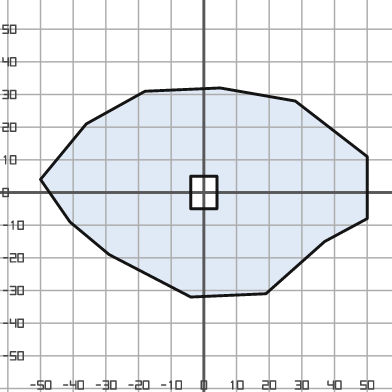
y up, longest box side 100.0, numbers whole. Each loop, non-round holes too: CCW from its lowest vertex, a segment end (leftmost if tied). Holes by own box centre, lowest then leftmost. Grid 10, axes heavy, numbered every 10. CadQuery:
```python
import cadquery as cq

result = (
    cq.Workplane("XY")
    .moveTo(-4.0, -32.0)
    .lineTo(19.0, -31.0)
    .lineTo(37.0, -15.0)
    .lineTo(50.0, -8.0)
    .lineTo(50.0, 11.0)
    .lineTo(28.0, 28.0)
    .lineTo(5.0, 32.0)
    .lineTo(-18.0, 31.0)
    .lineTo(-36.0, 21.0)
    .lineTo(-50.0, 4.0)
    .lineTo(-41.0, -9.0)
    .lineTo(-29.0, -19.0)
    .close()
    .moveTo(-4.0, -5.0)
    .lineTo(4.0, -5.0)
    .lineTo(4.0, 5.0)
    .lineTo(-4.0, 5.0)
    .close()
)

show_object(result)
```